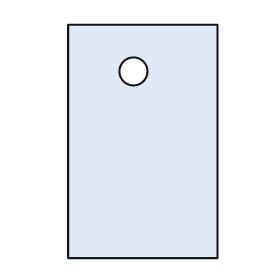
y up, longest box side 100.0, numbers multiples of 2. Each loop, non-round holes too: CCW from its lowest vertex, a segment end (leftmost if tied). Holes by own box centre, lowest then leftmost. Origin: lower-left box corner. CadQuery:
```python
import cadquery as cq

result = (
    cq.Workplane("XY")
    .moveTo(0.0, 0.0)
    .lineTo(64.0, 0.0)
    .lineTo(64.0, 100.0)
    .lineTo(0.0, 100.0)
    .close()
    .moveTo(28.0, 80.0)
    .circle(6.0)
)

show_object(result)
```